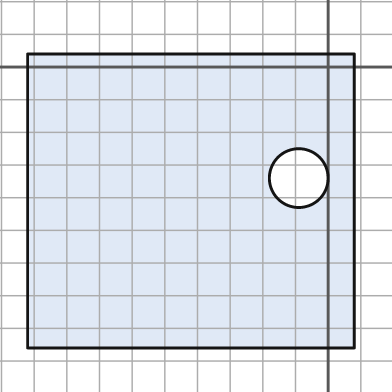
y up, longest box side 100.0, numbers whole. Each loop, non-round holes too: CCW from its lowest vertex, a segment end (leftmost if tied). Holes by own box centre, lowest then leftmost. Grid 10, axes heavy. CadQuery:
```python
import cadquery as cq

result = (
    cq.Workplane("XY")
    .moveTo(-92.0, -86.0)
    .lineTo(8.0, -86.0)
    .lineTo(8.0, 4.0)
    .lineTo(-92.0, 4.0)
    .close()
    .moveTo(-9.0, -34.0)
    .circle(9.0)
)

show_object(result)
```